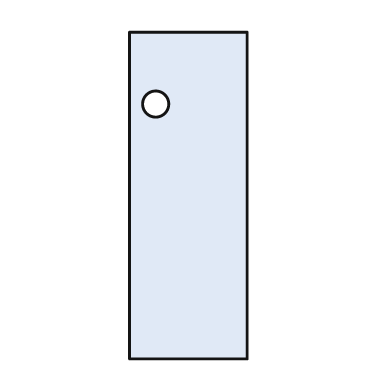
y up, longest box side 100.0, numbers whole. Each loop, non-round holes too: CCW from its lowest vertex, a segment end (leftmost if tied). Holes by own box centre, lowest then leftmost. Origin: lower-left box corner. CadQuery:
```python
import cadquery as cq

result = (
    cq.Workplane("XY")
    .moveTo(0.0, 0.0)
    .lineTo(36.0, 0.0)
    .lineTo(36.0, 100.0)
    .lineTo(0.0, 100.0)
    .close()
    .moveTo(8.0, 78.0)
    .circle(4.0)
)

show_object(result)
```